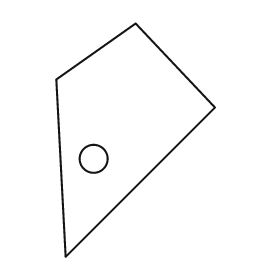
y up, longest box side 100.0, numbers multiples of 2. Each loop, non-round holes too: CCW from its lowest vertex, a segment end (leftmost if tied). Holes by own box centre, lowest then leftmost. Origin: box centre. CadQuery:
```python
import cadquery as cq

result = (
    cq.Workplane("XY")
    .moveTo(-30.0, -50.0)
    .lineTo(34.0, 14.0)
    .lineTo(0.0, 50.0)
    .lineTo(-34.0, 26.0)
    .close()
    .moveTo(-18.0, -8.0)
    .circle(6.0)
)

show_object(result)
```